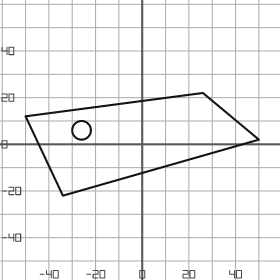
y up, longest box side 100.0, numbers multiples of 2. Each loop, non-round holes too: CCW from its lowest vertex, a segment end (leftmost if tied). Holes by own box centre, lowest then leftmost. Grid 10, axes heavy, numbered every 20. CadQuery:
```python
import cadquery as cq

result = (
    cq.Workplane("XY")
    .moveTo(-34.0, -22.0)
    .lineTo(50.0, 2.0)
    .lineTo(26.0, 22.0)
    .lineTo(-50.0, 12.0)
    .close()
    .moveTo(-26.0, 6.0)
    .circle(4.0)
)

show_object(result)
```